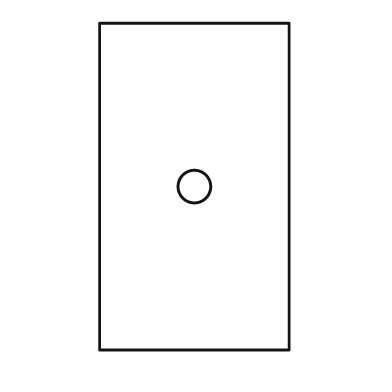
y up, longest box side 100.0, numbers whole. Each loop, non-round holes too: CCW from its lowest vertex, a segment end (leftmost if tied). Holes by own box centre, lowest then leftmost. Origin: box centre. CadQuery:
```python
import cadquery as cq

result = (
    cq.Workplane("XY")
    .moveTo(-29.0, -50.0)
    .lineTo(29.0, -50.0)
    .lineTo(29.0, 50.0)
    .lineTo(-29.0, 50.0)
    .close()
    .moveTo(0.0, 0.0)
    .circle(5.0)
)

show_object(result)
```